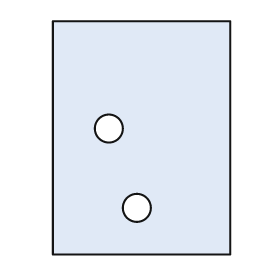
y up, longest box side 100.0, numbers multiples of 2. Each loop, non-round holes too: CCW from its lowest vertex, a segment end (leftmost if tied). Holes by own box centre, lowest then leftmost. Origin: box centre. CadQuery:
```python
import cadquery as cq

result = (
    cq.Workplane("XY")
    .moveTo(-38.0, -50.0)
    .lineTo(38.0, -50.0)
    .lineTo(38.0, 50.0)
    .lineTo(-38.0, 50.0)
    .close()
    .moveTo(-2.0, -30.0)
    .circle(6.0)
    .moveTo(-14.0, 4.0)
    .circle(6.0)
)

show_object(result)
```